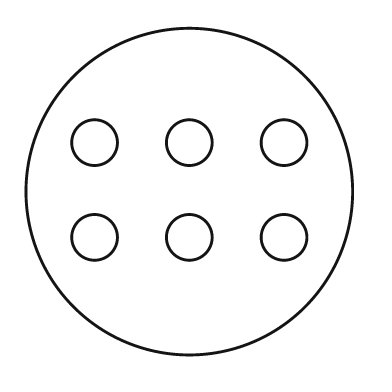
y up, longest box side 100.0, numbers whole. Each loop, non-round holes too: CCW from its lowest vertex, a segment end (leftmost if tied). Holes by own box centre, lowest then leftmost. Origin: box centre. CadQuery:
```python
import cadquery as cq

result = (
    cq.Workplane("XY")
    .moveTo(0.0, 0.0)
    .circle(50.0)
    .moveTo(-29.0, -14.0)
    .circle(7.0)
    .moveTo(0.0, -14.0)
    .circle(7.0)
    .moveTo(29.0, -14.0)
    .circle(7.0)
    .moveTo(-29.0, 15.0)
    .circle(7.0)
    .moveTo(0.0, 15.0)
    .circle(7.0)
    .moveTo(29.0, 15.0)
    .circle(7.0)
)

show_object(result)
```